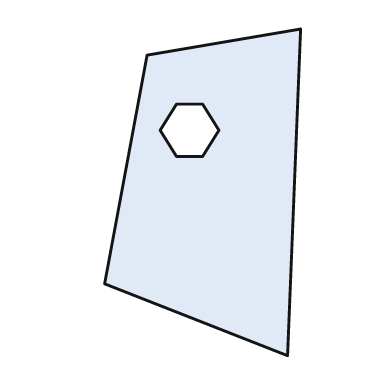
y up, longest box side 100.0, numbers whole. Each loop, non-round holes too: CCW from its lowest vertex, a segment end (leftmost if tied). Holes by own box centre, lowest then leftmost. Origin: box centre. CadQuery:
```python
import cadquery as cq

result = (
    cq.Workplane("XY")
    .moveTo(26.0, -50.0)
    .lineTo(30.0, 50.0)
    .lineTo(-17.0, 42.0)
    .lineTo(-30.0, -28.0)
    .close()
    .moveTo(-8.0, 11.0)
    .lineTo(0.0, 11.0)
    .lineTo(5.0, 19.0)
    .lineTo(0.0, 27.0)
    .lineTo(-8.0, 27.0)
    .lineTo(-13.0, 19.0)
    .close()
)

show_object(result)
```